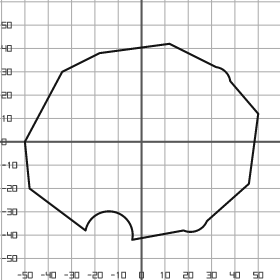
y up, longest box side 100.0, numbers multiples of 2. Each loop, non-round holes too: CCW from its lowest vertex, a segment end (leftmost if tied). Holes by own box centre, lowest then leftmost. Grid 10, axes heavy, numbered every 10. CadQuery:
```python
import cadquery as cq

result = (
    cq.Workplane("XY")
    .moveTo(-4.0, -42.0)
    .lineTo(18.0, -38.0)
    .threePointArc((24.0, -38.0), (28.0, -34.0))
    .lineTo(46.0, -18.0)
    .lineTo(50.0, 12.0)
    .lineTo(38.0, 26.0)
    .threePointArc((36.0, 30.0), (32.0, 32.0))
    .lineTo(12.0, 42.0)
    .lineTo(-18.0, 38.0)
    .lineTo(-34.0, 30.0)
    .lineTo(-50.0, 0.0)
    .lineTo(-48.0, -20.0)
    .lineTo(-24.0, -38.0)
    .threePointArc((-12.0, -30.0), (-4.0, -42.0))
    .close()
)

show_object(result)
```